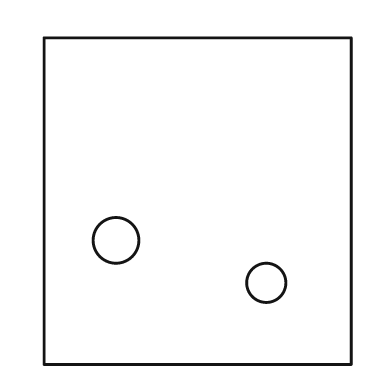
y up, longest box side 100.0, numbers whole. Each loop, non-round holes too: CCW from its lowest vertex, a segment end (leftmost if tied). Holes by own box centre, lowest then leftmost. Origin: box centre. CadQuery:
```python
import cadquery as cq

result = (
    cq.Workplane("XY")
    .moveTo(-47.0, -50.0)
    .lineTo(47.0, -50.0)
    .lineTo(47.0, 50.0)
    .lineTo(-47.0, 50.0)
    .close()
    .moveTo(21.0, -25.0)
    .circle(6.0)
    .moveTo(-25.0, -12.0)
    .circle(7.0)
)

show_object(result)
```